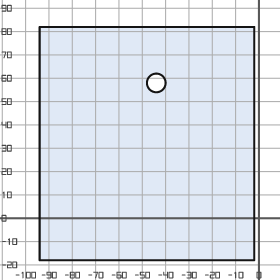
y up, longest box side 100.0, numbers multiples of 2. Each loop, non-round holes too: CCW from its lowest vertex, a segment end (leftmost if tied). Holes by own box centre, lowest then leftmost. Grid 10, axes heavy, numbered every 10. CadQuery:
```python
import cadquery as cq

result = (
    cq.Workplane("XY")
    .moveTo(-94.0, -18.0)
    .lineTo(-2.0, -18.0)
    .lineTo(-2.0, 82.0)
    .lineTo(-94.0, 82.0)
    .close()
    .moveTo(-44.0, 58.0)
    .circle(4.0)
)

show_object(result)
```